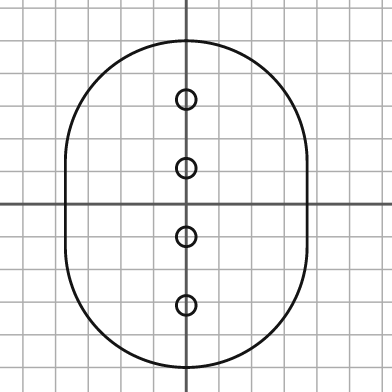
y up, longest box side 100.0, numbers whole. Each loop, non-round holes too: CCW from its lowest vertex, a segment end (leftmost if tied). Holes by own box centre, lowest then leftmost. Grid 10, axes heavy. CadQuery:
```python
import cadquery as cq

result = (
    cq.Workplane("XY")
    .moveTo(-37.0, -13.0)
    .threePointArc((0.0, -50.0), (37.0, -13.0))
    .lineTo(37.0, 13.0)
    .threePointArc((0.0, 50.0), (-37.0, 13.0))
    .close()
    .moveTo(0.0, -31.0)
    .circle(3.0)
    .moveTo(0.0, -10.0)
    .circle(3.0)
    .moveTo(0.0, 11.0)
    .circle(3.0)
    .moveTo(0.0, 32.0)
    .circle(3.0)
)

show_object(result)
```